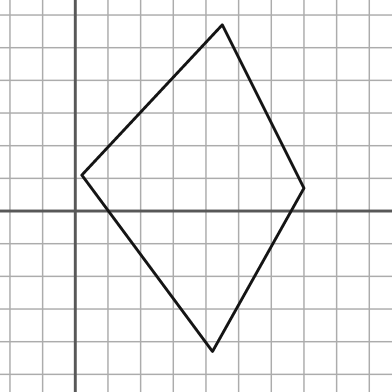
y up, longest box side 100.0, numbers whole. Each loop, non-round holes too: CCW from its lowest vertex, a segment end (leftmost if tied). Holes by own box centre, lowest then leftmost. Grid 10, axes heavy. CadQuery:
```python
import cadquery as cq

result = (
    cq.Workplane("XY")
    .moveTo(42.0, -43.0)
    .lineTo(70.0, 7.0)
    .lineTo(45.0, 57.0)
    .lineTo(2.0, 11.0)
    .close()
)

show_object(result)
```